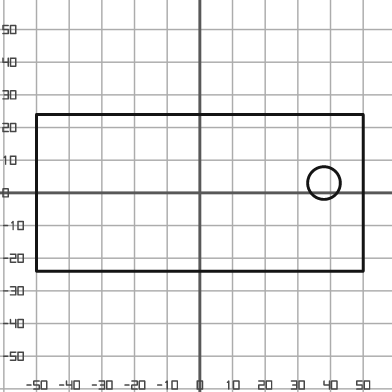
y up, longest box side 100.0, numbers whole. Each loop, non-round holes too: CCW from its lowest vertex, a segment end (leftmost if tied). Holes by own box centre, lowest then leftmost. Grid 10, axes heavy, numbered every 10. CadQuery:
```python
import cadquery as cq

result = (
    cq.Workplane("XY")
    .moveTo(-50.0, -24.0)
    .lineTo(50.0, -24.0)
    .lineTo(50.0, 24.0)
    .lineTo(-50.0, 24.0)
    .close()
    .moveTo(38.0, 3.0)
    .circle(5.0)
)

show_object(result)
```